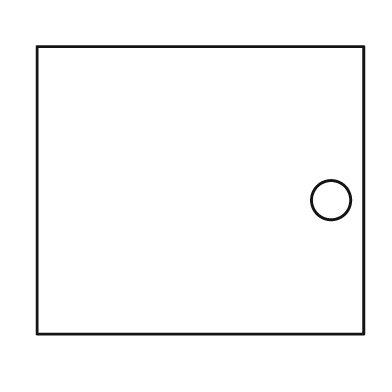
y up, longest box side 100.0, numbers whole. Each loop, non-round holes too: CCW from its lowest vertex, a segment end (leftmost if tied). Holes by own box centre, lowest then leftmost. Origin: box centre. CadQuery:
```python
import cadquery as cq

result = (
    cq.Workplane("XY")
    .moveTo(-50.0, -44.0)
    .lineTo(50.0, -44.0)
    .lineTo(50.0, 44.0)
    .lineTo(-50.0, 44.0)
    .close()
    .moveTo(40.0, -3.0)
    .circle(6.0)
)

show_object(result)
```